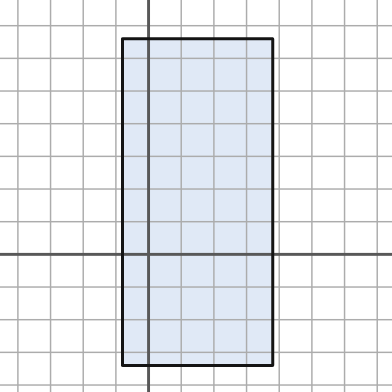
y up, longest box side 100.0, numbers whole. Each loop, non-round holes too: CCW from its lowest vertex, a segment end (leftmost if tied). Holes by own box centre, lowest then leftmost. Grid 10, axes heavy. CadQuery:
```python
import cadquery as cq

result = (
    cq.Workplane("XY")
    .moveTo(-8.0, -34.0)
    .lineTo(38.0, -34.0)
    .lineTo(38.0, 66.0)
    .lineTo(-8.0, 66.0)
    .close()
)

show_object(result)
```